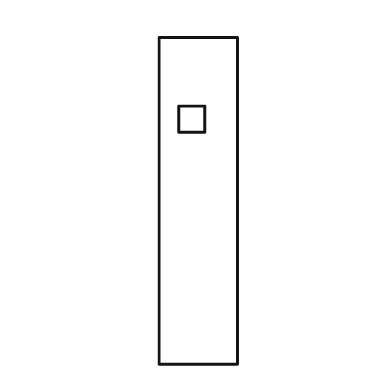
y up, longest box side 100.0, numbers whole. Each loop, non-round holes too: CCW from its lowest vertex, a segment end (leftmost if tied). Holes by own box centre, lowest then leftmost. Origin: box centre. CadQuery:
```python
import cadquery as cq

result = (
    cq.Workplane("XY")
    .moveTo(-12.0, -50.0)
    .lineTo(12.0, -50.0)
    .lineTo(12.0, 50.0)
    .lineTo(-12.0, 50.0)
    .close()
    .moveTo(-6.0, 21.0)
    .lineTo(2.0, 21.0)
    .lineTo(2.0, 29.0)
    .lineTo(-6.0, 29.0)
    .close()
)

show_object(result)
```